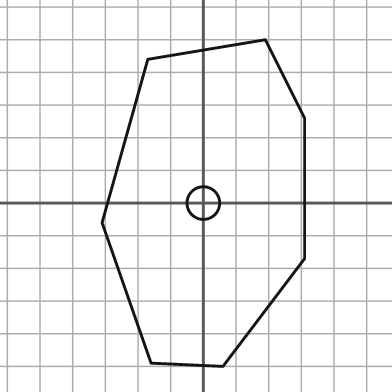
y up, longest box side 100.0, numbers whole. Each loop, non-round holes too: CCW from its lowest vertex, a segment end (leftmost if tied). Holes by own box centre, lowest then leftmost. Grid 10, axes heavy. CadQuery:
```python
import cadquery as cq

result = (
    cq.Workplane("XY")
    .moveTo(6.0, -50.0)
    .lineTo(31.0, -17.0)
    .lineTo(31.0, 26.0)
    .lineTo(19.0, 50.0)
    .lineTo(-17.0, 44.0)
    .lineTo(-31.0, -6.0)
    .lineTo(-16.0, -49.0)
    .close()
    .moveTo(0.0, 0.0)
    .circle(5.0)
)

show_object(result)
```